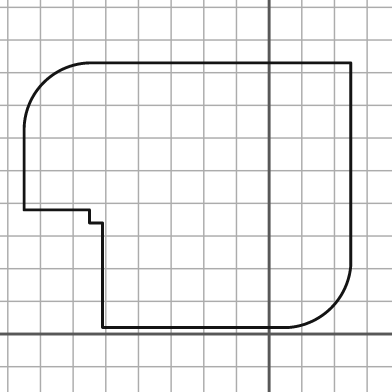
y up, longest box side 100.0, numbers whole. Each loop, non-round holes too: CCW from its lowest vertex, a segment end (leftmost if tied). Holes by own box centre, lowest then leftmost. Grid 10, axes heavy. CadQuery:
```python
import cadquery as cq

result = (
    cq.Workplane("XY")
    .moveTo(-51.0, 2.0)
    .lineTo(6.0, 2.0)
    .threePointArc((19.0, 8.0), (25.0, 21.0))
    .lineTo(25.0, 83.0)
    .lineTo(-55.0, 83.0)
    .threePointArc((-69.0, 77.0), (-75.0, 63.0))
    .lineTo(-75.0, 38.0)
    .lineTo(-55.0, 38.0)
    .lineTo(-55.0, 34.0)
    .lineTo(-51.0, 34.0)
    .close()
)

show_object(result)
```